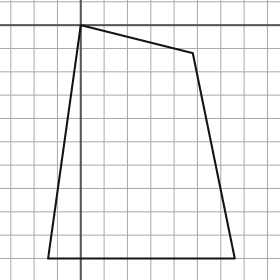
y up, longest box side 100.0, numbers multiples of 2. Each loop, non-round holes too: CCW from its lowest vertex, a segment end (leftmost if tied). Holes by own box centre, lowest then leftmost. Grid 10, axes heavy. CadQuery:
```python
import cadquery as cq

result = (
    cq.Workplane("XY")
    .moveTo(-14.0, -100.0)
    .lineTo(66.0, -100.0)
    .lineTo(48.0, -12.0)
    .lineTo(0.0, 0.0)
    .close()
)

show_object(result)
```